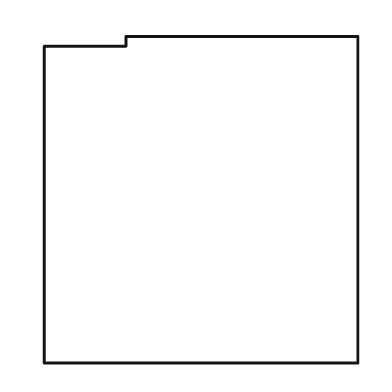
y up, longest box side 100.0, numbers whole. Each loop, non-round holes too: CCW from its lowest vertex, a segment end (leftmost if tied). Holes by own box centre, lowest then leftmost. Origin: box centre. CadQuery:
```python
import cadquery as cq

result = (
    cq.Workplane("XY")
    .moveTo(-48.0, -50.0)
    .lineTo(48.0, -50.0)
    .lineTo(48.0, 50.0)
    .lineTo(-23.0, 50.0)
    .lineTo(-23.0, 47.0)
    .lineTo(-48.0, 47.0)
    .close()
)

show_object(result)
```